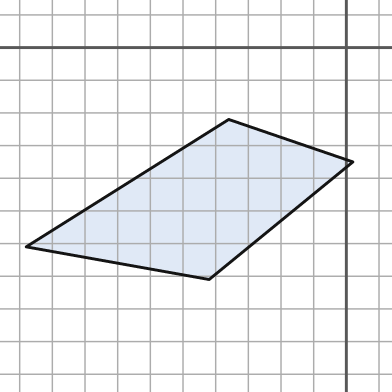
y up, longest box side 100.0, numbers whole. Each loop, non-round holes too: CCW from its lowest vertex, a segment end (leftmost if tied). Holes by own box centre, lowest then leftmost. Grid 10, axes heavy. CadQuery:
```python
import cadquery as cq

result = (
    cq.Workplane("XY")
    .moveTo(-42.0, -71.0)
    .lineTo(2.0, -35.0)
    .lineTo(-36.0, -22.0)
    .lineTo(-98.0, -61.0)
    .close()
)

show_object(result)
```